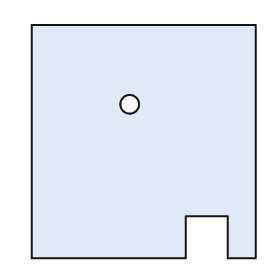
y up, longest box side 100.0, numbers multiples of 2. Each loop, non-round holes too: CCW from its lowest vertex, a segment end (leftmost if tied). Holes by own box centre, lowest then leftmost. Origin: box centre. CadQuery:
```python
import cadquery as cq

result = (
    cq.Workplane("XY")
    .moveTo(-48.0, -50.0)
    .lineTo(18.0, -50.0)
    .lineTo(18.0, -32.0)
    .lineTo(36.0, -32.0)
    .lineTo(36.0, -50.0)
    .lineTo(48.0, -50.0)
    .lineTo(48.0, 50.0)
    .lineTo(-48.0, 50.0)
    .close()
    .moveTo(-6.0, 16.0)
    .circle(4.0)
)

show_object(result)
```